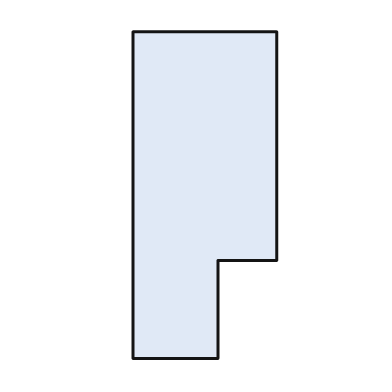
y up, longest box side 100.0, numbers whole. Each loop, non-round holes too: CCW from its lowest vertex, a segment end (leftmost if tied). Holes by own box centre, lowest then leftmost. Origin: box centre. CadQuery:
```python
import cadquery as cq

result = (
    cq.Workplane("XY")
    .moveTo(-22.0, -50.0)
    .lineTo(4.0, -50.0)
    .lineTo(4.0, -20.0)
    .lineTo(22.0, -20.0)
    .lineTo(22.0, 50.0)
    .lineTo(-22.0, 50.0)
    .close()
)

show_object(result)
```